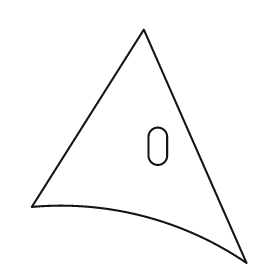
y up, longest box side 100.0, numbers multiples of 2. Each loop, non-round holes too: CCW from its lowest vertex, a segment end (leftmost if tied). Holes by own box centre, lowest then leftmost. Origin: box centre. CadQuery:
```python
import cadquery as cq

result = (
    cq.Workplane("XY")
    .moveTo(46.0, -50.0)
    .lineTo(2.0, 50.0)
    .lineTo(-46.0, -26.0)
    .threePointArc((2.0, -30.0), (46.0, -50.0))
    .close()
    .moveTo(4.0, -4.0)
    .threePointArc((8.0, -8.0), (12.0, -4.0))
    .lineTo(12.0, 4.0)
    .threePointArc((8.0, 8.0), (4.0, 4.0))
    .close()
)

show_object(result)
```